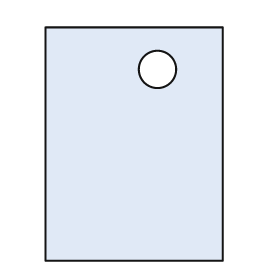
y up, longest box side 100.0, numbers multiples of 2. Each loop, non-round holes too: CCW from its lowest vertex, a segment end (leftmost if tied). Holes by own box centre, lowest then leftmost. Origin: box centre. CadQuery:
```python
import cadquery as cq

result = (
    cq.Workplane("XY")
    .moveTo(-38.0, -50.0)
    .lineTo(38.0, -50.0)
    .lineTo(38.0, 50.0)
    .lineTo(-38.0, 50.0)
    .close()
    .moveTo(10.0, 32.0)
    .circle(8.0)
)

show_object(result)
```